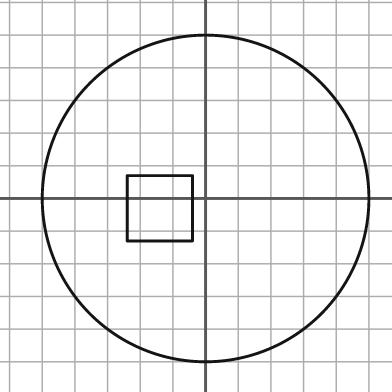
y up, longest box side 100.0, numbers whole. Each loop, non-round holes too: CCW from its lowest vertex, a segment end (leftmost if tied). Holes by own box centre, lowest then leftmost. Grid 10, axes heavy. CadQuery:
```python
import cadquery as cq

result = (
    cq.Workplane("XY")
    .moveTo(0.0, 0.0)
    .circle(50.0)
    .moveTo(-24.0, -13.0)
    .lineTo(-4.0, -13.0)
    .lineTo(-4.0, 7.0)
    .lineTo(-24.0, 7.0)
    .close()
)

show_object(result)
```